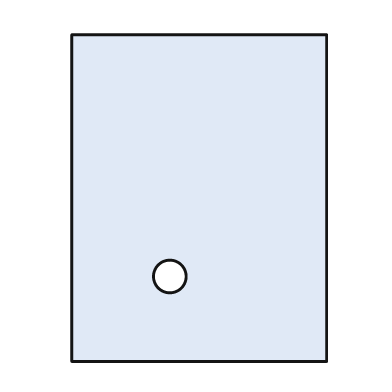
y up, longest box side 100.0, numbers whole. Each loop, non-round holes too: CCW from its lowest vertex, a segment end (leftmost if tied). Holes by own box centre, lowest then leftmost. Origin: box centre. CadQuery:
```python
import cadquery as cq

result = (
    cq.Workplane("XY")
    .moveTo(-39.0, -50.0)
    .lineTo(39.0, -50.0)
    .lineTo(39.0, 50.0)
    .lineTo(-39.0, 50.0)
    .close()
    .moveTo(-9.0, -24.0)
    .circle(5.0)
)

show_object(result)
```